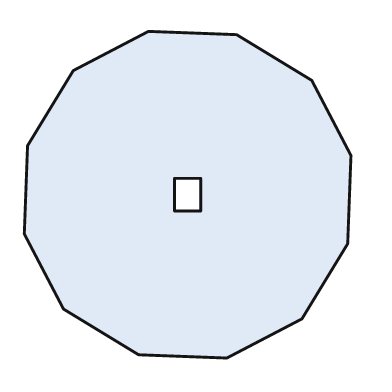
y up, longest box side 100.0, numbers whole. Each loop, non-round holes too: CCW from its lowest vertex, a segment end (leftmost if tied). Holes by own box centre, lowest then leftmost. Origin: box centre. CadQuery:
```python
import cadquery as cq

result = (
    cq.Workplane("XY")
    .moveTo(12.0, -50.0)
    .lineTo(35.0, -38.0)
    .lineTo(49.0, -15.0)
    .lineTo(50.0, 12.0)
    .lineTo(38.0, 35.0)
    .lineTo(15.0, 49.0)
    .lineTo(-12.0, 50.0)
    .lineTo(-35.0, 38.0)
    .lineTo(-49.0, 15.0)
    .lineTo(-50.0, -12.0)
    .lineTo(-38.0, -35.0)
    .lineTo(-15.0, -49.0)
    .close()
    .moveTo(-4.0, -5.0)
    .lineTo(4.0, -5.0)
    .lineTo(4.0, 5.0)
    .lineTo(-4.0, 5.0)
    .close()
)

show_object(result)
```